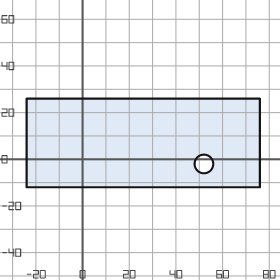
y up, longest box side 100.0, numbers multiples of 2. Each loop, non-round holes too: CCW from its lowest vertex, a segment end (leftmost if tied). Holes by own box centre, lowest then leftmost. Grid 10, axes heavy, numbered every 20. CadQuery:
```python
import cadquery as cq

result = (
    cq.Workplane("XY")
    .moveTo(-24.0, -12.0)
    .lineTo(76.0, -12.0)
    .lineTo(76.0, 26.0)
    .lineTo(-24.0, 26.0)
    .close()
    .moveTo(52.0, -2.0)
    .circle(4.0)
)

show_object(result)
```